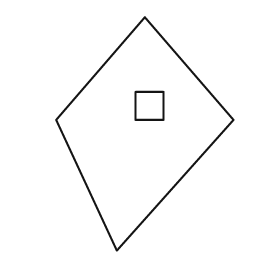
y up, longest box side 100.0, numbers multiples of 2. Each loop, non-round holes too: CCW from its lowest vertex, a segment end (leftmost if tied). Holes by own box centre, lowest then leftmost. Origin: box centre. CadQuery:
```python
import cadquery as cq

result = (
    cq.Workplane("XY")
    .moveTo(-12.0, -50.0)
    .lineTo(38.0, 6.0)
    .lineTo(0.0, 50.0)
    .lineTo(-38.0, 6.0)
    .close()
    .moveTo(-4.0, 6.0)
    .lineTo(8.0, 6.0)
    .lineTo(8.0, 18.0)
    .lineTo(-4.0, 18.0)
    .close()
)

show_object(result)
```